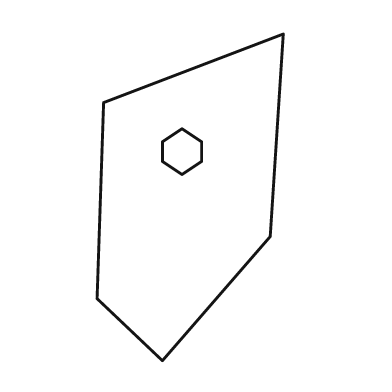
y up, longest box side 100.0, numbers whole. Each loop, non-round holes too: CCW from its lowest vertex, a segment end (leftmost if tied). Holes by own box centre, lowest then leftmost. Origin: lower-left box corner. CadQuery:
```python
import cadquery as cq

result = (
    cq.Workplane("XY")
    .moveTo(20.0, 0.0)
    .lineTo(53.0, 38.0)
    .lineTo(57.0, 100.0)
    .lineTo(2.0, 79.0)
    .lineTo(0.0, 19.0)
    .close()
    .moveTo(26.0, 57.0)
    .lineTo(32.0, 61.0)
    .lineTo(32.0, 67.0)
    .lineTo(26.0, 71.0)
    .lineTo(20.0, 67.0)
    .lineTo(20.0, 61.0)
    .close()
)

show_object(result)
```